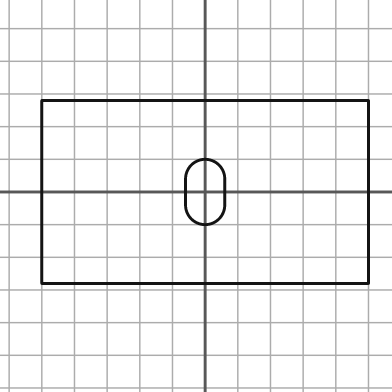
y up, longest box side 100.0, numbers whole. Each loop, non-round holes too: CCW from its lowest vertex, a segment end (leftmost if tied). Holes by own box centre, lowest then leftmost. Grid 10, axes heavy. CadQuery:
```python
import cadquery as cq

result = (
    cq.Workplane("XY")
    .moveTo(-50.0, -28.0)
    .lineTo(50.0, -28.0)
    .lineTo(50.0, 28.0)
    .lineTo(-50.0, 28.0)
    .close()
    .moveTo(-6.0, -4.0)
    .threePointArc((0.0, -10.0), (6.0, -4.0))
    .lineTo(6.0, 4.0)
    .threePointArc((0.0, 10.0), (-6.0, 4.0))
    .close()
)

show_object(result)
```